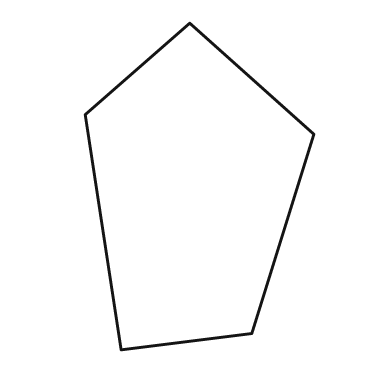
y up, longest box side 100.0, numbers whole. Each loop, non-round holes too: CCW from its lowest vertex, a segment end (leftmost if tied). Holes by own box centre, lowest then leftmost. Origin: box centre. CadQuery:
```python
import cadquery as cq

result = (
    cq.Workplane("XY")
    .moveTo(-24.0, -50.0)
    .lineTo(16.0, -45.0)
    .lineTo(35.0, 16.0)
    .lineTo(-3.0, 50.0)
    .lineTo(-35.0, 22.0)
    .close()
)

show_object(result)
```